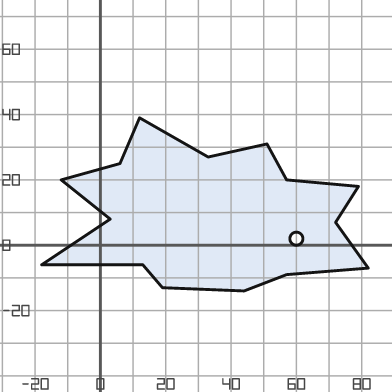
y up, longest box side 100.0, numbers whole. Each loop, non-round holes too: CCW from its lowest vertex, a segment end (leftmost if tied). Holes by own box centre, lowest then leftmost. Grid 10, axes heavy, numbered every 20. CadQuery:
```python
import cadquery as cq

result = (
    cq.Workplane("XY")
    .moveTo(44.0, -14.0)
    .lineTo(57.0, -9.0)
    .lineTo(82.0, -7.0)
    .lineTo(72.0, 7.0)
    .lineTo(79.0, 18.0)
    .lineTo(57.0, 20.0)
    .lineTo(51.0, 31.0)
    .lineTo(33.0, 27.0)
    .lineTo(12.0, 39.0)
    .lineTo(6.0, 25.0)
    .lineTo(-12.0, 20.0)
    .lineTo(3.0, 8.0)
    .lineTo(-18.0, -6.0)
    .lineTo(13.0, -6.0)
    .lineTo(19.0, -13.0)
    .close()
    .moveTo(60.0, 2.0)
    .circle(2.0)
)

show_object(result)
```